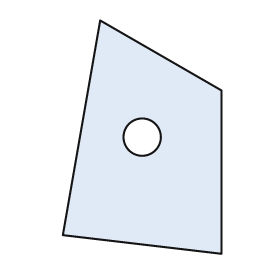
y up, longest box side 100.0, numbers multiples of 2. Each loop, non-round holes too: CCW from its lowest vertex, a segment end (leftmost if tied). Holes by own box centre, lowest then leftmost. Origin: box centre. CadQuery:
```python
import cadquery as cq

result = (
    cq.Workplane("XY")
    .moveTo(34.0, -50.0)
    .lineTo(34.0, 20.0)
    .lineTo(-18.0, 50.0)
    .lineTo(-34.0, -42.0)
    .close()
    .moveTo(0.0, 0.0)
    .circle(8.0)
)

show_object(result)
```